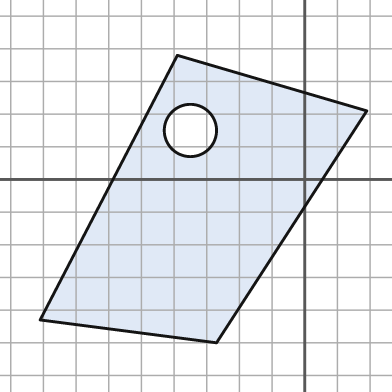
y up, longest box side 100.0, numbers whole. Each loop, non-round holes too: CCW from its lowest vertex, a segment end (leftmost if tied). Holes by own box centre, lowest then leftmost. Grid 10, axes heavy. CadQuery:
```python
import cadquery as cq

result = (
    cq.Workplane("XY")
    .moveTo(-27.0, -50.0)
    .lineTo(19.0, 21.0)
    .lineTo(-39.0, 38.0)
    .lineTo(-81.0, -43.0)
    .close()
    .moveTo(-35.0, 15.0)
    .circle(8.0)
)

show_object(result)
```